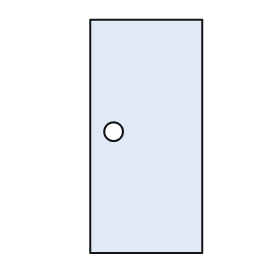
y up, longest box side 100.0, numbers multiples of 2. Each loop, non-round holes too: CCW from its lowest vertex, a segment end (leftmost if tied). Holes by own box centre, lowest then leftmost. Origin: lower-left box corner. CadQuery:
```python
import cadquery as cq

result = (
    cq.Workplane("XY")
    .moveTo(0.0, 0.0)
    .lineTo(48.0, 0.0)
    .lineTo(48.0, 100.0)
    .lineTo(0.0, 100.0)
    .close()
    .moveTo(10.0, 52.0)
    .circle(4.0)
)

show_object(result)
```